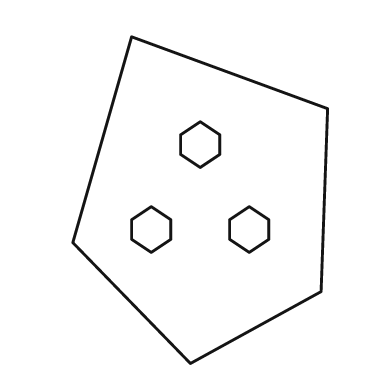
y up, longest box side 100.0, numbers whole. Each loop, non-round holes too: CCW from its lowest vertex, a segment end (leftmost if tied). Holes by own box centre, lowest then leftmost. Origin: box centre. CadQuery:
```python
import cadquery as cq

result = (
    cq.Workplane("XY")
    .moveTo(-3.0, -50.0)
    .lineTo(37.0, -28.0)
    .lineTo(39.0, 28.0)
    .lineTo(-21.0, 50.0)
    .lineTo(-39.0, -13.0)
    .close()
    .moveTo(-15.0, -16.0)
    .lineTo(-9.0, -12.0)
    .lineTo(-9.0, -6.0)
    .lineTo(-15.0, -2.0)
    .lineTo(-21.0, -6.0)
    .lineTo(-21.0, -12.0)
    .close()
    .moveTo(15.0, -16.0)
    .lineTo(21.0, -12.0)
    .lineTo(21.0, -6.0)
    .lineTo(15.0, -2.0)
    .lineTo(9.0, -6.0)
    .lineTo(9.0, -12.0)
    .close()
    .moveTo(0.0, 10.0)
    .lineTo(6.0, 14.0)
    .lineTo(6.0, 20.0)
    .lineTo(0.0, 24.0)
    .lineTo(-6.0, 20.0)
    .lineTo(-6.0, 14.0)
    .close()
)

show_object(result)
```